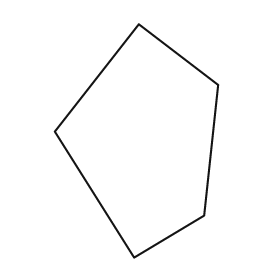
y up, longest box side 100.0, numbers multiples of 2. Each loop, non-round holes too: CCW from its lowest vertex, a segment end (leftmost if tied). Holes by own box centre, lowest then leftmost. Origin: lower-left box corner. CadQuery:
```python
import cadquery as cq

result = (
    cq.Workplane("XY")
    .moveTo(34.0, 0.0)
    .lineTo(64.0, 18.0)
    .lineTo(70.0, 74.0)
    .lineTo(36.0, 100.0)
    .lineTo(0.0, 54.0)
    .close()
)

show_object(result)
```